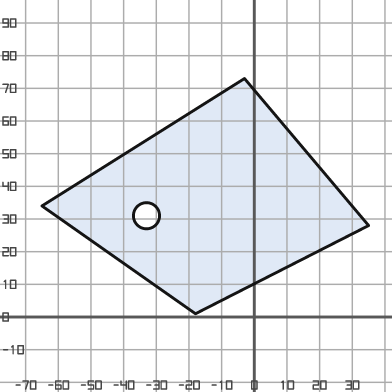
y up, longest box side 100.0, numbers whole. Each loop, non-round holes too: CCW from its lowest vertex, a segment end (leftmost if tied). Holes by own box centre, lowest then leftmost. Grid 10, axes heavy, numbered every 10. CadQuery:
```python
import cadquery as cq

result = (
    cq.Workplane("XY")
    .moveTo(-18.0, 1.0)
    .lineTo(35.0, 28.0)
    .lineTo(-3.0, 73.0)
    .lineTo(-65.0, 34.0)
    .close()
    .moveTo(-33.0, 31.0)
    .circle(4.0)
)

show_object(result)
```